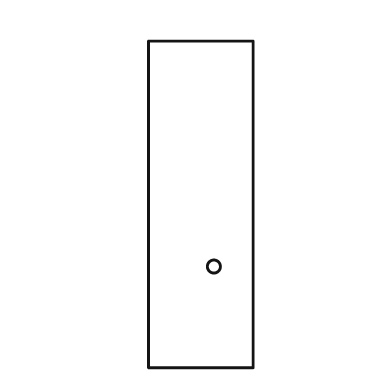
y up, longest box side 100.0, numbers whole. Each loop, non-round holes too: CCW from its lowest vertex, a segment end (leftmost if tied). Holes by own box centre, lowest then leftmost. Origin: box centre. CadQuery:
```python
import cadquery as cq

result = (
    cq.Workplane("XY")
    .moveTo(-16.0, -50.0)
    .lineTo(16.0, -50.0)
    .lineTo(16.0, 50.0)
    .lineTo(-16.0, 50.0)
    .close()
    .moveTo(4.0, -19.0)
    .circle(2.0)
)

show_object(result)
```